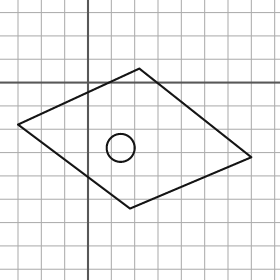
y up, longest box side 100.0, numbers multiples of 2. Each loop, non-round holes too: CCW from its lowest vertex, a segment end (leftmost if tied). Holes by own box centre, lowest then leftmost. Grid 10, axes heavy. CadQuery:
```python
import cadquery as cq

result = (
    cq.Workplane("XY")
    .moveTo(18.0, -54.0)
    .lineTo(70.0, -32.0)
    .lineTo(22.0, 6.0)
    .lineTo(-30.0, -18.0)
    .close()
    .moveTo(14.0, -28.0)
    .circle(6.0)
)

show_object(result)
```